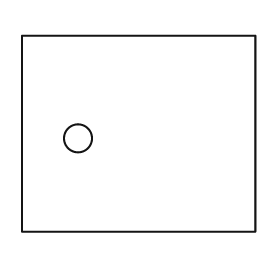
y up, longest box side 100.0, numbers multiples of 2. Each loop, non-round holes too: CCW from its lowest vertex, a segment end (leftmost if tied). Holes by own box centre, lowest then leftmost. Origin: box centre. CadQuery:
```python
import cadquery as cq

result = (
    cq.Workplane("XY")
    .moveTo(-50.0, -42.0)
    .lineTo(50.0, -42.0)
    .lineTo(50.0, 42.0)
    .lineTo(-50.0, 42.0)
    .close()
    .moveTo(-26.0, -2.0)
    .circle(6.0)
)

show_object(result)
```